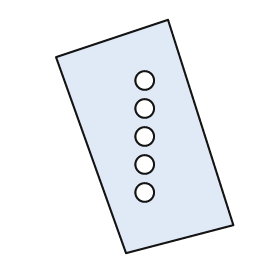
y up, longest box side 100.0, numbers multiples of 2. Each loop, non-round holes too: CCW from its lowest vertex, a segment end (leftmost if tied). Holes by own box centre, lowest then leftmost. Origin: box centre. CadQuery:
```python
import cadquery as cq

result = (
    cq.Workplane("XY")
    .moveTo(-8.0, -50.0)
    .lineTo(38.0, -38.0)
    .lineTo(10.0, 50.0)
    .lineTo(-38.0, 34.0)
    .close()
    .moveTo(0.0, -24.0)
    .circle(4.0)
    .moveTo(0.0, -12.0)
    .circle(4.0)
    .moveTo(0.0, 0.0)
    .circle(4.0)
    .moveTo(0.0, 12.0)
    .circle(4.0)
    .moveTo(0.0, 24.0)
    .circle(4.0)
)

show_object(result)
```